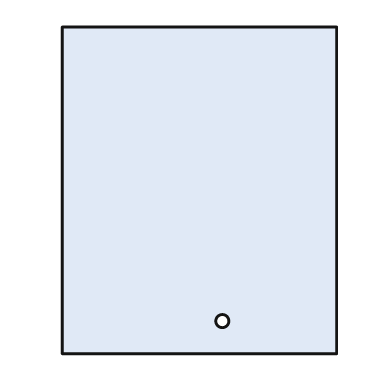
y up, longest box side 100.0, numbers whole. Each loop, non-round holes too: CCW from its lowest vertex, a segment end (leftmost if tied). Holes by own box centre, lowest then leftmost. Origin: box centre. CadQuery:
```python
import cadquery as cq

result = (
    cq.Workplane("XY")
    .moveTo(-42.0, -50.0)
    .lineTo(42.0, -50.0)
    .lineTo(42.0, 50.0)
    .lineTo(-42.0, 50.0)
    .close()
    .moveTo(7.0, -40.0)
    .circle(2.0)
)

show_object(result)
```